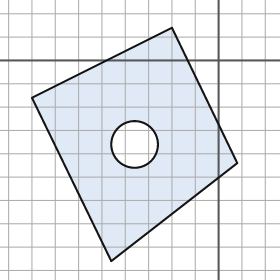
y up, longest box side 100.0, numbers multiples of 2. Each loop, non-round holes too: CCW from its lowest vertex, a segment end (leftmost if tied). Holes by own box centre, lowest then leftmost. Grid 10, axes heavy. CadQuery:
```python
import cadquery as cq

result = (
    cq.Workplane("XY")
    .moveTo(-46.0, -86.0)
    .lineTo(8.0, -44.0)
    .lineTo(-20.0, 14.0)
    .lineTo(-80.0, -16.0)
    .close()
    .moveTo(-36.0, -36.0)
    .circle(10.0)
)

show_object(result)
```